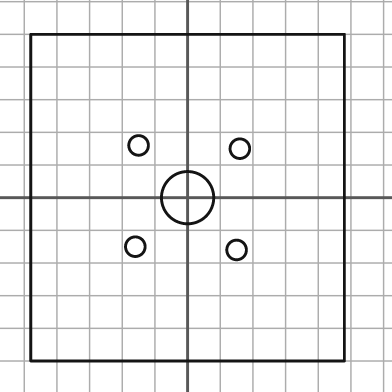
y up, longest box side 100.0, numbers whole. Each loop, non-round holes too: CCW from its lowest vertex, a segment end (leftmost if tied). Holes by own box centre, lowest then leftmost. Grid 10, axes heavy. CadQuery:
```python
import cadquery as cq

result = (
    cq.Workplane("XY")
    .moveTo(-48.0, -50.0)
    .lineTo(48.0, -50.0)
    .lineTo(48.0, 50.0)
    .lineTo(-48.0, 50.0)
    .close()
    .moveTo(15.0, -16.0)
    .circle(3.0)
    .moveTo(-16.0, -15.0)
    .circle(3.0)
    .moveTo(0.0, 0.0)
    .circle(8.0)
    .moveTo(16.0, 15.0)
    .circle(3.0)
    .moveTo(-15.0, 16.0)
    .circle(3.0)
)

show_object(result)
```